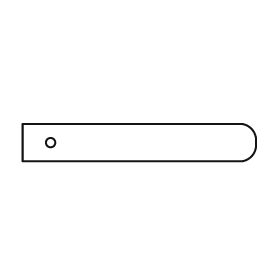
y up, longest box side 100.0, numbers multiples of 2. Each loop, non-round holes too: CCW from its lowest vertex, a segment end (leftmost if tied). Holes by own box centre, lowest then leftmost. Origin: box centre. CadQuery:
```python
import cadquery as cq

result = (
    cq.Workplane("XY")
    .moveTo(-50.0, -8.0)
    .lineTo(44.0, -8.0)
    .threePointArc((48.0, -6.0), (50.0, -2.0))
    .lineTo(50.0, 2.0)
    .threePointArc((48.0, 6.0), (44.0, 8.0))
    .lineTo(-50.0, 8.0)
    .close()
    .moveTo(-38.0, 0.0)
    .circle(2.0)
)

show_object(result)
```